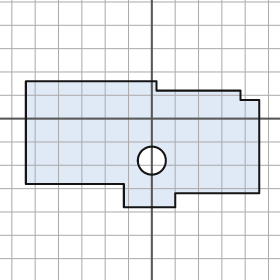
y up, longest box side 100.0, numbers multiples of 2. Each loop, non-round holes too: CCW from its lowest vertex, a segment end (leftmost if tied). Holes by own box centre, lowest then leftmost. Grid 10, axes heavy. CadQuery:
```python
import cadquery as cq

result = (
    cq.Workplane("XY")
    .moveTo(-12.0, -38.0)
    .lineTo(10.0, -38.0)
    .lineTo(10.0, -32.0)
    .lineTo(46.0, -32.0)
    .lineTo(46.0, 8.0)
    .lineTo(38.0, 8.0)
    .lineTo(38.0, 12.0)
    .lineTo(2.0, 12.0)
    .lineTo(2.0, 16.0)
    .lineTo(-54.0, 16.0)
    .lineTo(-54.0, -28.0)
    .lineTo(-12.0, -28.0)
    .close()
    .moveTo(0.0, -18.0)
    .circle(6.0)
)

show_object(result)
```